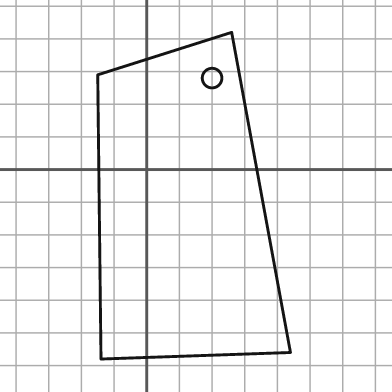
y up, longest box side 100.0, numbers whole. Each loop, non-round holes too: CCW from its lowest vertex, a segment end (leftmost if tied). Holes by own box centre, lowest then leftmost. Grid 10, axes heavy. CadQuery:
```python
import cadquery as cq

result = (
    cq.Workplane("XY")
    .moveTo(-14.0, -58.0)
    .lineTo(44.0, -56.0)
    .lineTo(26.0, 42.0)
    .lineTo(-15.0, 29.0)
    .close()
    .moveTo(20.0, 28.0)
    .circle(3.0)
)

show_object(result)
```